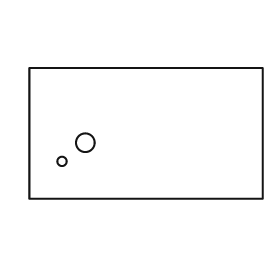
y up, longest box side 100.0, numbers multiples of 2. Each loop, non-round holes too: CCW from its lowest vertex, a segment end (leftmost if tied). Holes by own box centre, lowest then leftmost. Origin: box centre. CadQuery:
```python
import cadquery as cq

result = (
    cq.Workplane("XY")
    .moveTo(-50.0, -28.0)
    .lineTo(50.0, -28.0)
    .lineTo(50.0, 28.0)
    .lineTo(-50.0, 28.0)
    .close()
    .moveTo(-36.0, -12.0)
    .circle(2.0)
    .moveTo(-26.0, -4.0)
    .circle(4.0)
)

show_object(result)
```